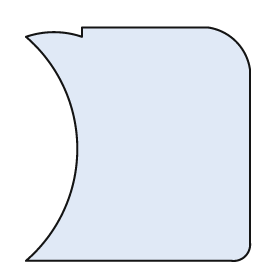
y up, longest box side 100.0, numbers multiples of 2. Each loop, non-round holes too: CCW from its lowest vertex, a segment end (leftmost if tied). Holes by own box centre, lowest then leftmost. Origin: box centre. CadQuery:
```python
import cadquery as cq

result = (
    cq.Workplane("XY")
    .moveTo(-48.0, -50.0)
    .lineTo(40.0, -50.0)
    .threePointArc((46.0, -48.0), (48.0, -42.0))
    .lineTo(48.0, 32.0)
    .threePointArc((42.0, 44.0), (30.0, 50.0))
    .lineTo(-24.0, 50.0)
    .lineTo(-24.0, 46.0)
    .threePointArc((-36.0, 48.0), (-48.0, 46.0))
    .threePointArc((-26.0, -2.0), (-48.0, -50.0))
    .close()
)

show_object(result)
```